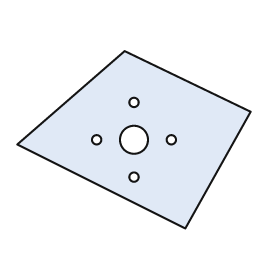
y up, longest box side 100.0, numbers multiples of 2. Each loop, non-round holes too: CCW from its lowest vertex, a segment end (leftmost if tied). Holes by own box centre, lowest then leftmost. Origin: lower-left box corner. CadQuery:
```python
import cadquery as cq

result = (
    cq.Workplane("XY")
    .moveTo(72.0, 0.0)
    .lineTo(100.0, 50.0)
    .lineTo(46.0, 76.0)
    .lineTo(0.0, 36.0)
    .close()
    .moveTo(50.0, 22.0)
    .circle(2.0)
    .moveTo(34.0, 38.0)
    .circle(2.0)
    .moveTo(50.0, 38.0)
    .circle(6.0)
    .moveTo(66.0, 38.0)
    .circle(2.0)
    .moveTo(50.0, 54.0)
    .circle(2.0)
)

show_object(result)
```